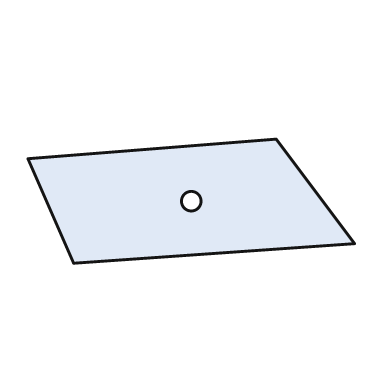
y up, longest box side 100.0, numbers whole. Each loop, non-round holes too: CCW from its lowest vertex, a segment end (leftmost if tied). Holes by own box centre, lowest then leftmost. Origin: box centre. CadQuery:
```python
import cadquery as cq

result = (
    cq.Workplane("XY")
    .moveTo(-36.0, -19.0)
    .lineTo(50.0, -13.0)
    .lineTo(26.0, 19.0)
    .lineTo(-50.0, 13.0)
    .close()
    .moveTo(0.0, 0.0)
    .circle(3.0)
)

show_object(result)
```